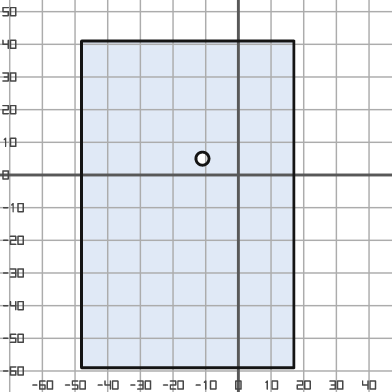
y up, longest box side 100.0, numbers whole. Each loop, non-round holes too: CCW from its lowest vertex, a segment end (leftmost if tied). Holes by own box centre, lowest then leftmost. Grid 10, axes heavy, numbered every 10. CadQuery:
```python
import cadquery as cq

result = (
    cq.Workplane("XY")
    .moveTo(-48.0, -59.0)
    .lineTo(17.0, -59.0)
    .lineTo(17.0, 41.0)
    .lineTo(-48.0, 41.0)
    .close()
    .moveTo(-11.0, 5.0)
    .circle(2.0)
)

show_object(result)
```